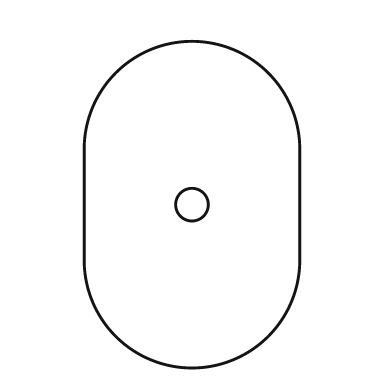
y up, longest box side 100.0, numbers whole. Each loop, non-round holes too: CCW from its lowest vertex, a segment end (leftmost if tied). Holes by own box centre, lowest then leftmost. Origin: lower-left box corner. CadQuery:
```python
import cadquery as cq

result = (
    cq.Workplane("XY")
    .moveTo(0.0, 33.0)
    .threePointArc((33.0, 0.0), (66.0, 33.0))
    .lineTo(66.0, 67.0)
    .threePointArc((33.0, 100.0), (0.0, 67.0))
    .close()
    .moveTo(33.0, 50.0)
    .circle(5.0)
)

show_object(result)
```